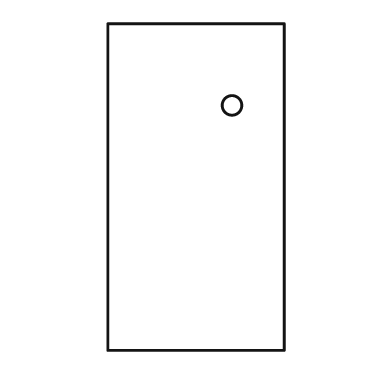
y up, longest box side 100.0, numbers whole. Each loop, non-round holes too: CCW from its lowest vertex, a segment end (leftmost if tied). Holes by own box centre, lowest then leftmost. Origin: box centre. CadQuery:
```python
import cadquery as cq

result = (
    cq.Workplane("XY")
    .moveTo(-27.0, -50.0)
    .lineTo(27.0, -50.0)
    .lineTo(27.0, 50.0)
    .lineTo(-27.0, 50.0)
    .close()
    .moveTo(11.0, 25.0)
    .circle(3.0)
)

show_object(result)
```